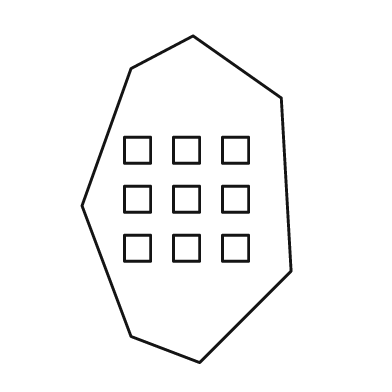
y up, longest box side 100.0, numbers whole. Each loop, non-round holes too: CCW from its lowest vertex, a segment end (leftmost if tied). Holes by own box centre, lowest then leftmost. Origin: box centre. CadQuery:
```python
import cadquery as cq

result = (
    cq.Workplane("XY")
    .moveTo(4.0, -50.0)
    .lineTo(32.0, -22.0)
    .lineTo(29.0, 31.0)
    .lineTo(2.0, 50.0)
    .lineTo(-17.0, 40.0)
    .lineTo(-32.0, -2.0)
    .lineTo(-17.0, -42.0)
    .close()
    .moveTo(-19.0, -19.0)
    .lineTo(-11.0, -19.0)
    .lineTo(-11.0, -11.0)
    .lineTo(-19.0, -11.0)
    .close()
    .moveTo(-4.0, -19.0)
    .lineTo(4.0, -19.0)
    .lineTo(4.0, -11.0)
    .lineTo(-4.0, -11.0)
    .close()
    .moveTo(11.0, -19.0)
    .lineTo(19.0, -19.0)
    .lineTo(19.0, -11.0)
    .lineTo(11.0, -11.0)
    .close()
    .moveTo(-19.0, -4.0)
    .lineTo(-11.0, -4.0)
    .lineTo(-11.0, 4.0)
    .lineTo(-19.0, 4.0)
    .close()
    .moveTo(-4.0, -4.0)
    .lineTo(4.0, -4.0)
    .lineTo(4.0, 4.0)
    .lineTo(-4.0, 4.0)
    .close()
    .moveTo(11.0, -4.0)
    .lineTo(19.0, -4.0)
    .lineTo(19.0, 4.0)
    .lineTo(11.0, 4.0)
    .close()
    .moveTo(-19.0, 11.0)
    .lineTo(-11.0, 11.0)
    .lineTo(-11.0, 19.0)
    .lineTo(-19.0, 19.0)
    .close()
    .moveTo(-4.0, 11.0)
    .lineTo(4.0, 11.0)
    .lineTo(4.0, 19.0)
    .lineTo(-4.0, 19.0)
    .close()
    .moveTo(11.0, 11.0)
    .lineTo(19.0, 11.0)
    .lineTo(19.0, 19.0)
    .lineTo(11.0, 19.0)
    .close()
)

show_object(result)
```